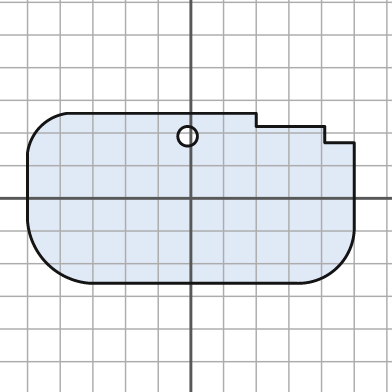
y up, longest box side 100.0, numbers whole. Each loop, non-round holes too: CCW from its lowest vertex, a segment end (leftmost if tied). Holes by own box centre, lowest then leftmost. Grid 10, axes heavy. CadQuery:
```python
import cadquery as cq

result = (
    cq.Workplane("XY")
    .moveTo(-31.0, -26.0)
    .lineTo(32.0, -26.0)
    .threePointArc((45.0, -21.0), (50.0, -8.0))
    .lineTo(50.0, 17.0)
    .lineTo(41.0, 17.0)
    .lineTo(41.0, 22.0)
    .lineTo(20.0, 22.0)
    .lineTo(20.0, 26.0)
    .lineTo(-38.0, 26.0)
    .threePointArc((-46.0, 22.0), (-50.0, 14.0))
    .lineTo(-50.0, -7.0)
    .threePointArc((-44.0, -20.0), (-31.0, -26.0))
    .close()
    .moveTo(-1.0, 19.0)
    .circle(3.0)
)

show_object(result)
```